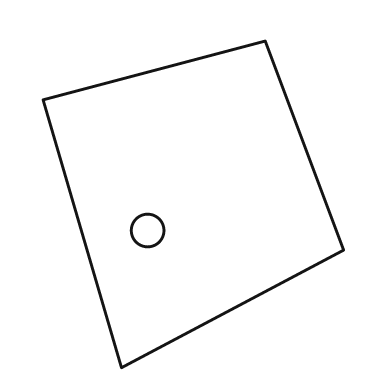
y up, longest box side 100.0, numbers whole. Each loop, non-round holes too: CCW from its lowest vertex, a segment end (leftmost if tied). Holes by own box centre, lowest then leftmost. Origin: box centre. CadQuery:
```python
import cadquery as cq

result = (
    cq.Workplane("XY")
    .moveTo(-22.0, -50.0)
    .lineTo(46.0, -14.0)
    .lineTo(22.0, 50.0)
    .lineTo(-46.0, 32.0)
    .close()
    .moveTo(-14.0, -8.0)
    .circle(5.0)
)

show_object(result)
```